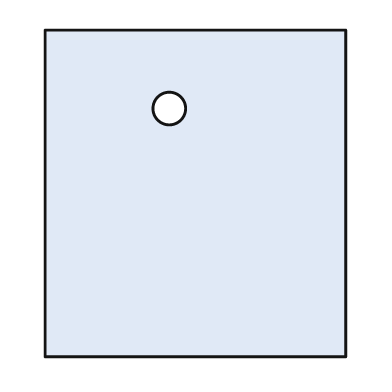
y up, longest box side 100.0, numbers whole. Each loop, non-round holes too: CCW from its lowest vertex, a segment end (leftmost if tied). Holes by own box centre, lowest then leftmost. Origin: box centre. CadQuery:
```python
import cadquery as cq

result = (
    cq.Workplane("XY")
    .moveTo(-46.0, -50.0)
    .lineTo(46.0, -50.0)
    .lineTo(46.0, 50.0)
    .lineTo(-46.0, 50.0)
    .close()
    .moveTo(-8.0, 26.0)
    .circle(5.0)
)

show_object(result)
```